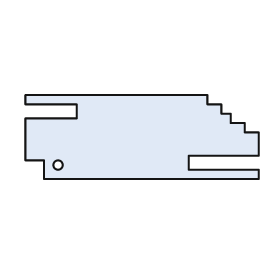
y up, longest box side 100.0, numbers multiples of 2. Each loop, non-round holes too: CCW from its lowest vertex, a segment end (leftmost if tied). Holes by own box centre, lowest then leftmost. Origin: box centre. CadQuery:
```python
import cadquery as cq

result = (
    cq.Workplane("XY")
    .moveTo(-42.0, -18.0)
    .lineTo(50.0, -18.0)
    .lineTo(50.0, -14.0)
    .lineTo(20.0, -14.0)
    .lineTo(20.0, -8.0)
    .lineTo(50.0, -8.0)
    .lineTo(50.0, 2.0)
    .lineTo(44.0, 2.0)
    .lineTo(44.0, 6.0)
    .lineTo(38.0, 6.0)
    .lineTo(38.0, 10.0)
    .lineTo(34.0, 10.0)
    .lineTo(34.0, 14.0)
    .lineTo(28.0, 14.0)
    .lineTo(28.0, 18.0)
    .lineTo(-50.0, 18.0)
    .lineTo(-50.0, 14.0)
    .lineTo(-28.0, 14.0)
    .lineTo(-28.0, 8.0)
    .lineTo(-50.0, 8.0)
    .lineTo(-50.0, -10.0)
    .lineTo(-42.0, -10.0)
    .close()
    .moveTo(-36.0, -12.0)
    .circle(2.0)
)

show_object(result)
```